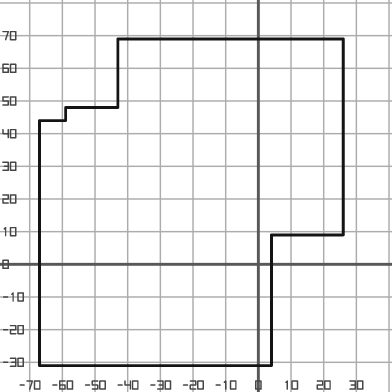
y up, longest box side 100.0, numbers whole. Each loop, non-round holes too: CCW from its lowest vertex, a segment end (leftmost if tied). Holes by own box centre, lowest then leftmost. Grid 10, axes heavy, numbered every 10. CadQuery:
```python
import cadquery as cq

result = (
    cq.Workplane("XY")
    .moveTo(-67.0, -31.0)
    .lineTo(4.0, -31.0)
    .lineTo(4.0, 9.0)
    .lineTo(26.0, 9.0)
    .lineTo(26.0, 69.0)
    .lineTo(-43.0, 69.0)
    .lineTo(-43.0, 48.0)
    .lineTo(-59.0, 48.0)
    .lineTo(-59.0, 44.0)
    .lineTo(-67.0, 44.0)
    .close()
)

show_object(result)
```